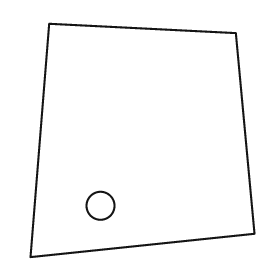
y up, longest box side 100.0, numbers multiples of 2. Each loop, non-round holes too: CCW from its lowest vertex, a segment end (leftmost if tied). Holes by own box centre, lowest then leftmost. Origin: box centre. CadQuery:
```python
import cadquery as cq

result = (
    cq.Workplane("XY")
    .moveTo(-48.0, -50.0)
    .lineTo(48.0, -40.0)
    .lineTo(40.0, 46.0)
    .lineTo(-40.0, 50.0)
    .close()
    .moveTo(-18.0, -28.0)
    .circle(6.0)
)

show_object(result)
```